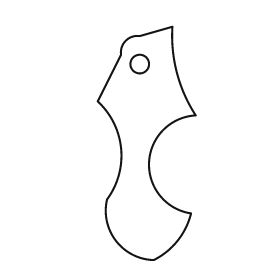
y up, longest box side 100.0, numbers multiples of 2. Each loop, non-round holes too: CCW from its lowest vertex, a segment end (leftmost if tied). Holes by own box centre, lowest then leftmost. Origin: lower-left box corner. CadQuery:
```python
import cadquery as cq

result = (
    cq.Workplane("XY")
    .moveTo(24.0, 0.0)
    .threePointArc((34.0, 8.0), (40.0, 20.0))
    .threePointArc((22.0, 42.0), (42.0, 62.0))
    .threePointArc((34.0, 80.0), (32.0, 100.0))
    .lineTo(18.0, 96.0)
    .threePointArc((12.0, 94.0), (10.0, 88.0))
    .lineTo(0.0, 68.0)
    .threePointArc((10.0, 48.0), (4.0, 26.0))
    .threePointArc((8.0, 8.0), (24.0, 0.0))
    .close()
    .moveTo(18.0, 84.0)
    .circle(4.0)
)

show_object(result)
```